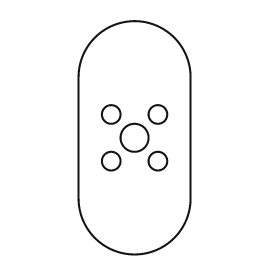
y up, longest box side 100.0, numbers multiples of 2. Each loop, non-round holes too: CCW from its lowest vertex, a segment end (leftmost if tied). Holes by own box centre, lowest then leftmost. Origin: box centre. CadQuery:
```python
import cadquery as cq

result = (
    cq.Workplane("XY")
    .moveTo(-24.0, -26.0)
    .threePointArc((0.0, -50.0), (24.0, -26.0))
    .lineTo(24.0, 26.0)
    .threePointArc((0.0, 50.0), (-24.0, 26.0))
    .close()
    .moveTo(-10.0, -10.0)
    .circle(4.0)
    .moveTo(10.0, -10.0)
    .circle(4.0)
    .moveTo(0.0, 0.0)
    .circle(6.0)
    .moveTo(-10.0, 10.0)
    .circle(4.0)
    .moveTo(10.0, 10.0)
    .circle(4.0)
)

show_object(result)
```